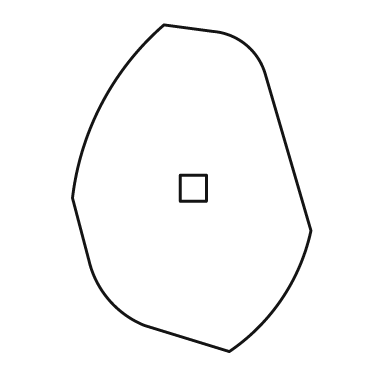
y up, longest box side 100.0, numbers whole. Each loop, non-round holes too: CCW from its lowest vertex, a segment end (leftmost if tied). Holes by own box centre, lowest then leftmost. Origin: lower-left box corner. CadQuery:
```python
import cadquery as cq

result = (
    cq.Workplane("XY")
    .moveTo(48.0, 0.0)
    .threePointArc((64.0, 16.0), (73.0, 37.0))
    .lineTo(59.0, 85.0)
    .threePointArc((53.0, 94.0), (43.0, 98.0))
    .lineTo(28.0, 100.0)
    .threePointArc((9.0, 76.0), (0.0, 47.0))
    .lineTo(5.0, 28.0)
    .threePointArc((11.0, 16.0), (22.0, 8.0))
    .close()
    .moveTo(33.0, 46.0)
    .lineTo(41.0, 46.0)
    .lineTo(41.0, 54.0)
    .lineTo(33.0, 54.0)
    .close()
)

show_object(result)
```